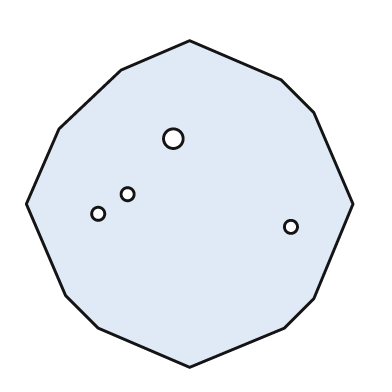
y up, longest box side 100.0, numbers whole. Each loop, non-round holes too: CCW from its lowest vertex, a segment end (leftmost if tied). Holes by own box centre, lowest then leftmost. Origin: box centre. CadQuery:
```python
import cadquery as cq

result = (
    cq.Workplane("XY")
    .moveTo(0.0, -50.0)
    .lineTo(29.0, -38.0)
    .lineTo(38.0, -29.0)
    .lineTo(50.0, 0.0)
    .lineTo(38.0, 28.0)
    .lineTo(28.0, 38.0)
    .lineTo(0.0, 50.0)
    .lineTo(-21.0, 41.0)
    .lineTo(-40.0, 23.0)
    .lineTo(-50.0, 0.0)
    .lineTo(-38.0, -28.0)
    .lineTo(-28.0, -38.0)
    .close()
    .moveTo(31.0, -7.0)
    .circle(2.0)
    .moveTo(-28.0, -3.0)
    .circle(2.0)
    .moveTo(-19.0, 3.0)
    .circle(2.0)
    .moveTo(-5.0, 20.0)
    .circle(3.0)
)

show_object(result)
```